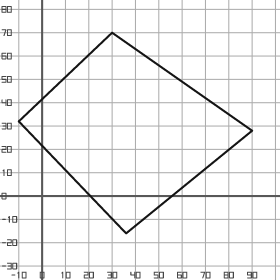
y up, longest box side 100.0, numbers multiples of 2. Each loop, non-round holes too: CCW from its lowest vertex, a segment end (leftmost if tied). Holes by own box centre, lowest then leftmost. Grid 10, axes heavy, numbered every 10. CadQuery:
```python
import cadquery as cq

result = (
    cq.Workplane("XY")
    .moveTo(36.0, -16.0)
    .lineTo(90.0, 28.0)
    .lineTo(30.0, 70.0)
    .lineTo(-10.0, 32.0)
    .close()
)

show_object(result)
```